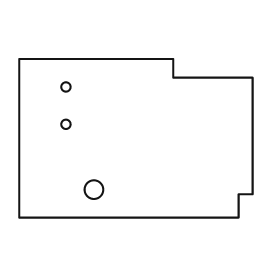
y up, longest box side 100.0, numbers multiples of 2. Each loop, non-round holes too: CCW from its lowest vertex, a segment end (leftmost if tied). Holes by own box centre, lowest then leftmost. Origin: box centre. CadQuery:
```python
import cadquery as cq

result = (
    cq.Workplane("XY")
    .moveTo(-50.0, -34.0)
    .lineTo(44.0, -34.0)
    .lineTo(44.0, -24.0)
    .lineTo(50.0, -24.0)
    .lineTo(50.0, 26.0)
    .lineTo(16.0, 26.0)
    .lineTo(16.0, 34.0)
    .lineTo(-50.0, 34.0)
    .close()
    .moveTo(-18.0, -22.0)
    .circle(4.0)
    .moveTo(-30.0, 6.0)
    .circle(2.0)
    .moveTo(-30.0, 22.0)
    .circle(2.0)
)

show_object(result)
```